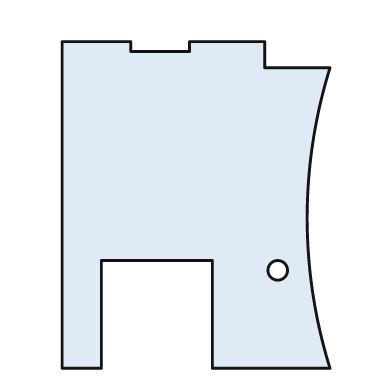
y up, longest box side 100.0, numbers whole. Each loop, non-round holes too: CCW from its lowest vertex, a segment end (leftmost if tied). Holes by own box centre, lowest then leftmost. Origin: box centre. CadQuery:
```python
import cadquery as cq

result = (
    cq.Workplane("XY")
    .moveTo(-41.0, -50.0)
    .lineTo(-29.0, -50.0)
    .lineTo(-29.0, -17.0)
    .lineTo(5.0, -17.0)
    .lineTo(5.0, -50.0)
    .lineTo(41.0, -50.0)
    .threePointArc((34.0, -4.0), (41.0, 42.0))
    .lineTo(21.0, 42.0)
    .lineTo(21.0, 50.0)
    .lineTo(-2.0, 50.0)
    .lineTo(-2.0, 47.0)
    .lineTo(-20.0, 47.0)
    .lineTo(-20.0, 50.0)
    .lineTo(-41.0, 50.0)
    .close()
    .moveTo(25.0, -20.0)
    .circle(3.0)
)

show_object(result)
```